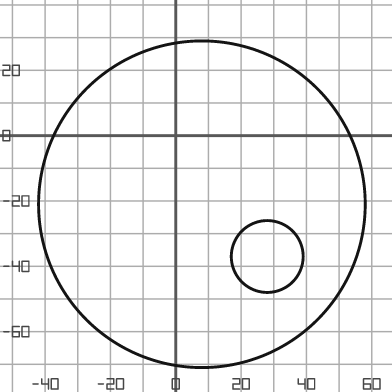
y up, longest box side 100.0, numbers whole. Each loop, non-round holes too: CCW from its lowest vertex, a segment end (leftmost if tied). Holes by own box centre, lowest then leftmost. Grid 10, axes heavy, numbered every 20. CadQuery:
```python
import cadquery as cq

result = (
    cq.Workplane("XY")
    .moveTo(8.0, -21.0)
    .circle(50.0)
    .moveTo(28.0, -37.0)
    .circle(11.0)
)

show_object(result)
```